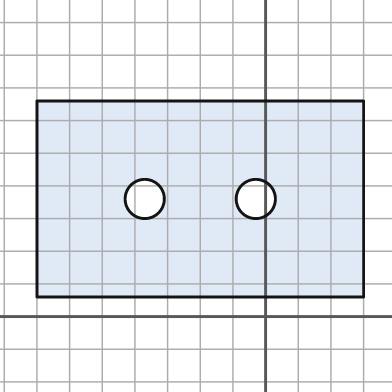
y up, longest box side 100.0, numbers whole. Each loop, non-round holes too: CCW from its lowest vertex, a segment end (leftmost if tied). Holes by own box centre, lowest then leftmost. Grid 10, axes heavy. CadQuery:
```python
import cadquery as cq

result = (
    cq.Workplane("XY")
    .moveTo(-70.0, 6.0)
    .lineTo(30.0, 6.0)
    .lineTo(30.0, 66.0)
    .lineTo(-70.0, 66.0)
    .close()
    .moveTo(-37.0, 36.0)
    .circle(6.0)
    .moveTo(-3.0, 36.0)
    .circle(6.0)
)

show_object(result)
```